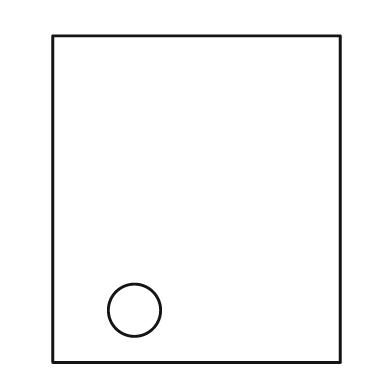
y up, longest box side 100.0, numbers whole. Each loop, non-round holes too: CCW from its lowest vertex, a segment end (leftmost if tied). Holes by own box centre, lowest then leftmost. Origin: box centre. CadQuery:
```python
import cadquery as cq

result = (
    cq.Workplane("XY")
    .moveTo(-44.0, -50.0)
    .lineTo(44.0, -50.0)
    .lineTo(44.0, 50.0)
    .lineTo(-44.0, 50.0)
    .close()
    .moveTo(-19.0, -34.0)
    .circle(8.0)
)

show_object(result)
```